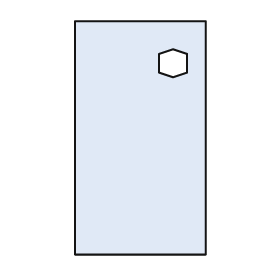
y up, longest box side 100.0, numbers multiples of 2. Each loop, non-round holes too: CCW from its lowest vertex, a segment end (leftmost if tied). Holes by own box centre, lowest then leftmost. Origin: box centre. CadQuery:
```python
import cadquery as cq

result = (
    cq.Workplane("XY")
    .moveTo(-28.0, -50.0)
    .lineTo(28.0, -50.0)
    .lineTo(28.0, 50.0)
    .lineTo(-28.0, 50.0)
    .close()
    .moveTo(14.0, 26.0)
    .lineTo(20.0, 28.0)
    .lineTo(20.0, 36.0)
    .lineTo(14.0, 38.0)
    .lineTo(8.0, 36.0)
    .lineTo(8.0, 28.0)
    .close()
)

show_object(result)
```